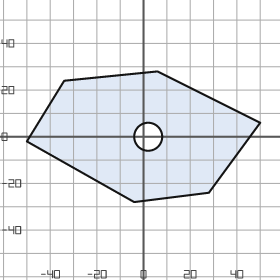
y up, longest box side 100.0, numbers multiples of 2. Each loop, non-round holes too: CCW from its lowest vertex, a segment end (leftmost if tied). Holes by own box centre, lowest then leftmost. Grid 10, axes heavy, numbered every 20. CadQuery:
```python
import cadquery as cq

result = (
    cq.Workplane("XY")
    .moveTo(-4.0, -28.0)
    .lineTo(28.0, -24.0)
    .lineTo(50.0, 6.0)
    .lineTo(6.0, 28.0)
    .lineTo(-34.0, 24.0)
    .lineTo(-50.0, -2.0)
    .close()
    .moveTo(2.0, 0.0)
    .circle(6.0)
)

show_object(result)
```